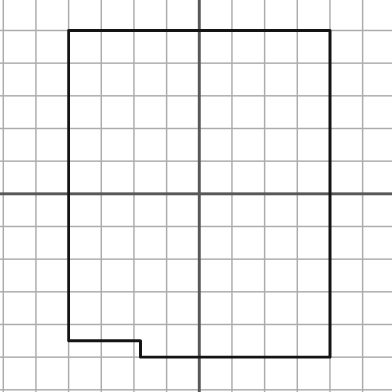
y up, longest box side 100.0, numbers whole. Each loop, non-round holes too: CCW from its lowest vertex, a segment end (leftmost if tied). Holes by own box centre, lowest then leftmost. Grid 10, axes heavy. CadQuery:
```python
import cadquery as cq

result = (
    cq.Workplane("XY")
    .moveTo(-18.0, -50.0)
    .lineTo(40.0, -50.0)
    .lineTo(40.0, 50.0)
    .lineTo(-40.0, 50.0)
    .lineTo(-40.0, -45.0)
    .lineTo(-18.0, -45.0)
    .close()
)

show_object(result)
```